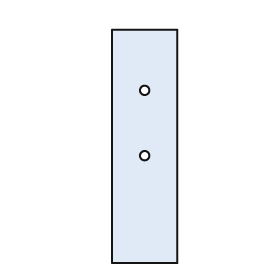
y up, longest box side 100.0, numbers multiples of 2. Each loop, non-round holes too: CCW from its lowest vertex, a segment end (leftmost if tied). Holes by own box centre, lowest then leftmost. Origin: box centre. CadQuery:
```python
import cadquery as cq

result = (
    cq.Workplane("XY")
    .moveTo(-14.0, -50.0)
    .lineTo(14.0, -50.0)
    .lineTo(14.0, 50.0)
    .lineTo(-14.0, 50.0)
    .close()
    .moveTo(0.0, -4.0)
    .circle(2.0)
    .moveTo(0.0, 24.0)
    .circle(2.0)
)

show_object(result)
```